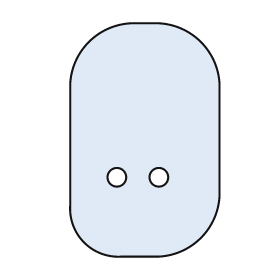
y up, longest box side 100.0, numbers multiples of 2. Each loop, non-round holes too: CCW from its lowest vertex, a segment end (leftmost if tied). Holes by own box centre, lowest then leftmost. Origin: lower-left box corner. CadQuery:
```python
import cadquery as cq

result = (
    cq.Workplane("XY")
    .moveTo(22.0, 0.0)
    .lineTo(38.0, 0.0)
    .threePointArc((56.0, 8.0), (64.0, 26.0))
    .lineTo(64.0, 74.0)
    .threePointArc((56.0, 92.0), (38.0, 100.0))
    .lineTo(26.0, 100.0)
    .threePointArc((8.0, 92.0), (0.0, 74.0))
    .lineTo(0.0, 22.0)
    .threePointArc((6.0, 6.0), (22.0, 0.0))
    .close()
    .moveTo(20.0, 34.0)
    .circle(4.0)
    .moveTo(38.0, 34.0)
    .circle(4.0)
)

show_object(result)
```